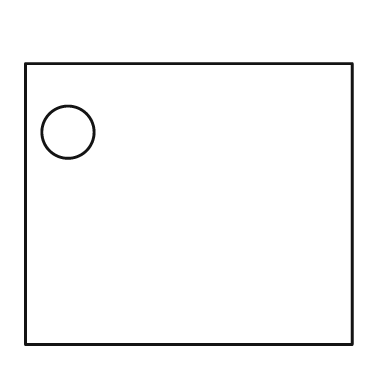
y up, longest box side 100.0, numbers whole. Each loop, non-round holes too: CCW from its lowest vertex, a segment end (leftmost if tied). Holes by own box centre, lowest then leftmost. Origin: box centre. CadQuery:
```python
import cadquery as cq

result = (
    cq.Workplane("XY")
    .moveTo(-50.0, -43.0)
    .lineTo(50.0, -43.0)
    .lineTo(50.0, 43.0)
    .lineTo(-50.0, 43.0)
    .close()
    .moveTo(-37.0, 22.0)
    .circle(8.0)
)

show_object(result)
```